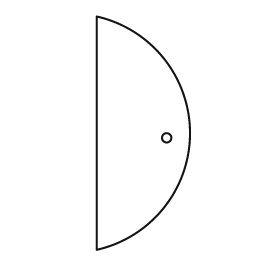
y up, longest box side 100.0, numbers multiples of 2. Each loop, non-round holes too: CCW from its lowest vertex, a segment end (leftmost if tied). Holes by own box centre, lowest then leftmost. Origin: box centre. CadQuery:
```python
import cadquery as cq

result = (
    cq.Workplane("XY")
    .moveTo(-20.0, -50.0)
    .threePointArc((20.0, 0.0), (-20.0, 50.0))
    .close()
    .moveTo(10.0, -2.0)
    .circle(2.0)
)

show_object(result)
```